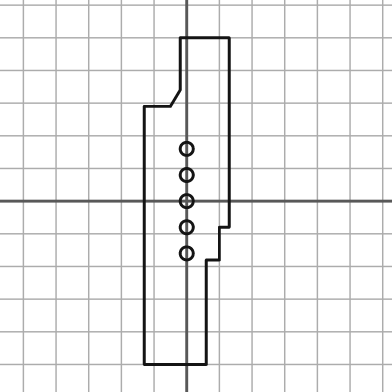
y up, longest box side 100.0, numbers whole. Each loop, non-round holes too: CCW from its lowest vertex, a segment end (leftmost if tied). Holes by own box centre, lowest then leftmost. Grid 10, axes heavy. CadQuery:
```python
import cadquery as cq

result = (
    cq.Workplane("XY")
    .moveTo(-13.0, -50.0)
    .lineTo(6.0, -50.0)
    .lineTo(6.0, -18.0)
    .lineTo(10.0, -18.0)
    .lineTo(10.0, -8.0)
    .lineTo(13.0, -8.0)
    .lineTo(13.0, 50.0)
    .lineTo(-2.0, 50.0)
    .lineTo(-2.0, 34.0)
    .lineTo(-5.0, 29.0)
    .lineTo(-13.0, 29.0)
    .close()
    .moveTo(0.0, -16.0)
    .circle(2.0)
    .moveTo(0.0, -8.0)
    .circle(2.0)
    .moveTo(0.0, 0.0)
    .circle(2.0)
    .moveTo(0.0, 8.0)
    .circle(2.0)
    .moveTo(0.0, 16.0)
    .circle(2.0)
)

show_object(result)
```